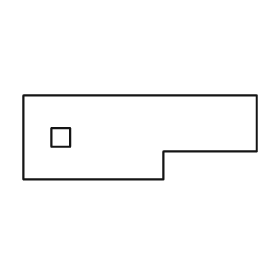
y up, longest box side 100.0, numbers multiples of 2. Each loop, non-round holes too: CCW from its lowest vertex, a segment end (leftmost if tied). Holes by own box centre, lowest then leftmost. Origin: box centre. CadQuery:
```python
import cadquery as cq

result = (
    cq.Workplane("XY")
    .moveTo(-50.0, -18.0)
    .lineTo(10.0, -18.0)
    .lineTo(10.0, -6.0)
    .lineTo(50.0, -6.0)
    .lineTo(50.0, 18.0)
    .lineTo(-50.0, 18.0)
    .close()
    .moveTo(-38.0, -4.0)
    .lineTo(-30.0, -4.0)
    .lineTo(-30.0, 4.0)
    .lineTo(-38.0, 4.0)
    .close()
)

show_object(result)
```